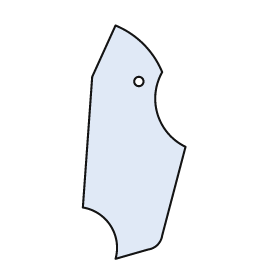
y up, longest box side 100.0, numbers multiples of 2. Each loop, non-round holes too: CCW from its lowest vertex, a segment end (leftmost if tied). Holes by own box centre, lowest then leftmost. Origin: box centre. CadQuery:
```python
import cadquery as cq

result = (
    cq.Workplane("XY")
    .moveTo(-8.0, -50.0)
    .lineTo(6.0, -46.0)
    .threePointArc((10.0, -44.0), (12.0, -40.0))
    .lineTo(22.0, -2.0)
    .threePointArc((10.0, 12.0), (12.0, 30.0))
    .threePointArc((4.0, 42.0), (-8.0, 50.0))
    .lineTo(-18.0, 28.0)
    .lineTo(-22.0, -28.0)
    .threePointArc((-10.0, -36.0), (-8.0, -50.0))
    .close()
    .moveTo(2.0, 26.0)
    .circle(2.0)
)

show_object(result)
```